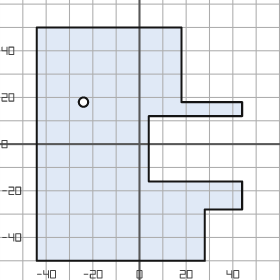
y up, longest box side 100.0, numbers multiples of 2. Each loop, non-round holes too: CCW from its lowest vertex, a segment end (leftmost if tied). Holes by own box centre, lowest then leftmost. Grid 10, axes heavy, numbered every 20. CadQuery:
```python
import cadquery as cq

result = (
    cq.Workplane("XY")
    .moveTo(-44.0, -50.0)
    .lineTo(28.0, -50.0)
    .lineTo(28.0, -28.0)
    .lineTo(44.0, -28.0)
    .lineTo(44.0, -16.0)
    .lineTo(4.0, -16.0)
    .lineTo(4.0, 12.0)
    .lineTo(44.0, 12.0)
    .lineTo(44.0, 18.0)
    .lineTo(18.0, 18.0)
    .lineTo(18.0, 50.0)
    .lineTo(-44.0, 50.0)
    .close()
    .moveTo(-24.0, 18.0)
    .circle(2.0)
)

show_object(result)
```